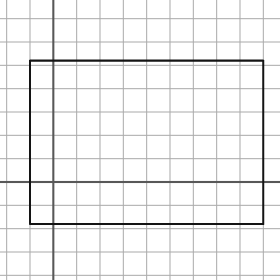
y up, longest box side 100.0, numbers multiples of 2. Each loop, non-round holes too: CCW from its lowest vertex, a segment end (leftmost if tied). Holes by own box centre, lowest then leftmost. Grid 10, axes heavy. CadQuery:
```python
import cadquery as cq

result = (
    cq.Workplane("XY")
    .moveTo(-10.0, -18.0)
    .lineTo(90.0, -18.0)
    .lineTo(90.0, 52.0)
    .lineTo(-10.0, 52.0)
    .close()
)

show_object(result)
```